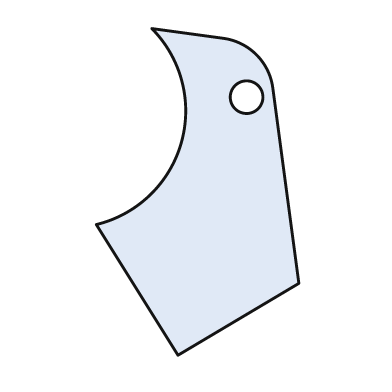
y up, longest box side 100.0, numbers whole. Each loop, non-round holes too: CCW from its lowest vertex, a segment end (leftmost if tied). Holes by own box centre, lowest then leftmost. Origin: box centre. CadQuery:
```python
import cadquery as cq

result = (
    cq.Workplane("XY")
    .moveTo(-6.0, -50.0)
    .lineTo(31.0, -28.0)
    .lineTo(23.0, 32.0)
    .threePointArc((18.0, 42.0), (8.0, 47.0))
    .lineTo(-14.0, 50.0)
    .threePointArc((-5.0, 15.0), (-31.0, -10.0))
    .close()
    .moveTo(15.0, 29.0)
    .circle(5.0)
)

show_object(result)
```